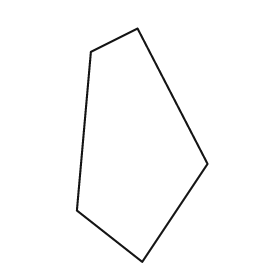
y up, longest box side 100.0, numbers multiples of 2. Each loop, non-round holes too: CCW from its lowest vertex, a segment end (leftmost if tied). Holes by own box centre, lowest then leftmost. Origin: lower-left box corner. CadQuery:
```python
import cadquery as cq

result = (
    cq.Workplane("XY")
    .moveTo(28.0, 0.0)
    .lineTo(56.0, 42.0)
    .lineTo(26.0, 100.0)
    .lineTo(6.0, 90.0)
    .lineTo(0.0, 22.0)
    .close()
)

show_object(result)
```